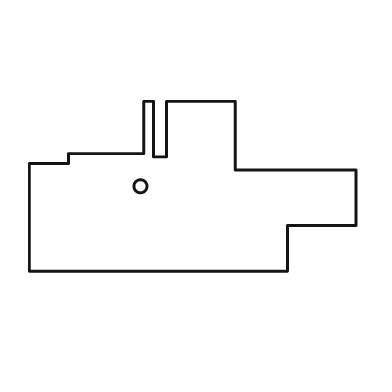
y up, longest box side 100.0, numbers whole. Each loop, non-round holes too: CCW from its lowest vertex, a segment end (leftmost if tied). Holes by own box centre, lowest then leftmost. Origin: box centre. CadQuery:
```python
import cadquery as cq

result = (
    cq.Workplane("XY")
    .moveTo(-50.0, -26.0)
    .lineTo(29.0, -26.0)
    .lineTo(29.0, -12.0)
    .lineTo(50.0, -12.0)
    .lineTo(50.0, 5.0)
    .lineTo(13.0, 5.0)
    .lineTo(13.0, 26.0)
    .lineTo(-8.0, 26.0)
    .lineTo(-8.0, 9.0)
    .lineTo(-12.0, 9.0)
    .lineTo(-12.0, 26.0)
    .lineTo(-15.0, 26.0)
    .lineTo(-15.0, 10.0)
    .lineTo(-38.0, 10.0)
    .lineTo(-38.0, 7.0)
    .lineTo(-50.0, 7.0)
    .close()
    .moveTo(-16.0, 0.0)
    .circle(2.0)
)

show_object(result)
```